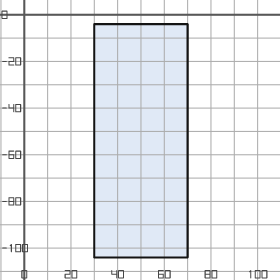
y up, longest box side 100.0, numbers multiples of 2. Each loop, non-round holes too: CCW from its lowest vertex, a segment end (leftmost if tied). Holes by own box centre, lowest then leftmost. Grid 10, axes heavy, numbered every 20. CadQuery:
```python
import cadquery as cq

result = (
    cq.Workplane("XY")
    .moveTo(30.0, -104.0)
    .lineTo(70.0, -104.0)
    .lineTo(70.0, -4.0)
    .lineTo(30.0, -4.0)
    .close()
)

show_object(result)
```